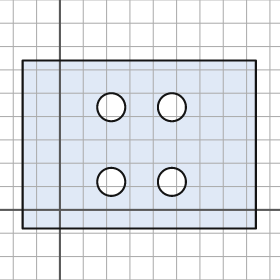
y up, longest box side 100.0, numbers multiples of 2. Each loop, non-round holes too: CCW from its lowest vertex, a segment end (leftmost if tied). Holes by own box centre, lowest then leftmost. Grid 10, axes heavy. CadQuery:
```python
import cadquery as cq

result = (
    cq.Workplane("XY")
    .moveTo(-16.0, -8.0)
    .lineTo(84.0, -8.0)
    .lineTo(84.0, 64.0)
    .lineTo(-16.0, 64.0)
    .close()
    .moveTo(22.0, 12.0)
    .circle(6.0)
    .moveTo(48.0, 12.0)
    .circle(6.0)
    .moveTo(22.0, 44.0)
    .circle(6.0)
    .moveTo(48.0, 44.0)
    .circle(6.0)
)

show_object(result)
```